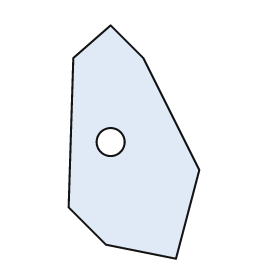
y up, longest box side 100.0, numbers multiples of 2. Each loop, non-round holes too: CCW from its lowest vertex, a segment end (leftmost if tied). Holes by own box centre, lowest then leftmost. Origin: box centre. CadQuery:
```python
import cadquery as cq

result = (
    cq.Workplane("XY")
    .moveTo(18.0, -50.0)
    .lineTo(28.0, -12.0)
    .lineTo(4.0, 36.0)
    .lineTo(-10.0, 50.0)
    .lineTo(-26.0, 36.0)
    .lineTo(-28.0, -28.0)
    .lineTo(-12.0, -44.0)
    .close()
    .moveTo(-10.0, 0.0)
    .circle(6.0)
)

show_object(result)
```